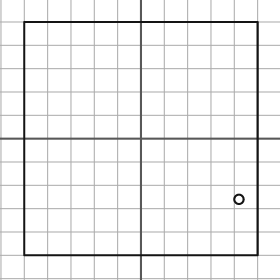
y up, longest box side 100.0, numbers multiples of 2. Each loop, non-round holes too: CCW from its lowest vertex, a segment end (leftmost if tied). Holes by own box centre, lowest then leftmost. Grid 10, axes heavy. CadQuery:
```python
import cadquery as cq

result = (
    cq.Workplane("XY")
    .moveTo(-50.0, -50.0)
    .lineTo(50.0, -50.0)
    .lineTo(50.0, 50.0)
    .lineTo(-50.0, 50.0)
    .close()
    .moveTo(42.0, -26.0)
    .circle(2.0)
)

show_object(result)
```